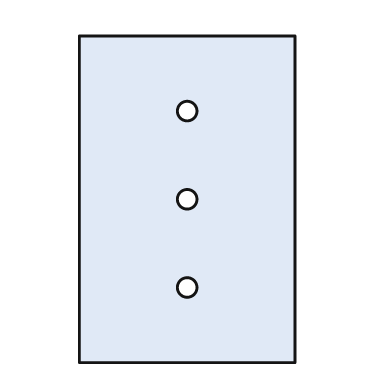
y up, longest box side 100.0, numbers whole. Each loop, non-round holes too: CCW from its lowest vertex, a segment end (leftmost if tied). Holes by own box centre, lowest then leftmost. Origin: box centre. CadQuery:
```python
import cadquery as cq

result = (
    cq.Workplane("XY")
    .moveTo(-33.0, -50.0)
    .lineTo(33.0, -50.0)
    .lineTo(33.0, 50.0)
    .lineTo(-33.0, 50.0)
    .close()
    .moveTo(0.0, -27.0)
    .circle(3.0)
    .moveTo(0.0, 0.0)
    .circle(3.0)
    .moveTo(0.0, 27.0)
    .circle(3.0)
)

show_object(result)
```